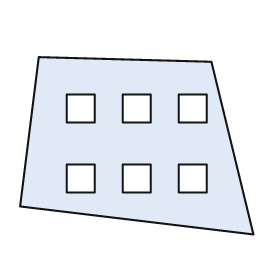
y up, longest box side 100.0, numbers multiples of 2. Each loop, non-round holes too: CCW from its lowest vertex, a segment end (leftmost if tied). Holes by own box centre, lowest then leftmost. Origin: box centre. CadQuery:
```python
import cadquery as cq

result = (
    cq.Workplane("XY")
    .moveTo(50.0, -38.0)
    .lineTo(32.0, 36.0)
    .lineTo(-42.0, 38.0)
    .lineTo(-50.0, -26.0)
    .close()
    .moveTo(-30.0, -20.0)
    .lineTo(-18.0, -20.0)
    .lineTo(-18.0, -8.0)
    .lineTo(-30.0, -8.0)
    .close()
    .moveTo(-6.0, -20.0)
    .lineTo(6.0, -20.0)
    .lineTo(6.0, -8.0)
    .lineTo(-6.0, -8.0)
    .close()
    .moveTo(18.0, -20.0)
    .lineTo(30.0, -20.0)
    .lineTo(30.0, -8.0)
    .lineTo(18.0, -8.0)
    .close()
    .moveTo(-30.0, 10.0)
    .lineTo(-18.0, 10.0)
    .lineTo(-18.0, 22.0)
    .lineTo(-30.0, 22.0)
    .close()
    .moveTo(-6.0, 10.0)
    .lineTo(6.0, 10.0)
    .lineTo(6.0, 22.0)
    .lineTo(-6.0, 22.0)
    .close()
    .moveTo(18.0, 10.0)
    .lineTo(30.0, 10.0)
    .lineTo(30.0, 22.0)
    .lineTo(18.0, 22.0)
    .close()
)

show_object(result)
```